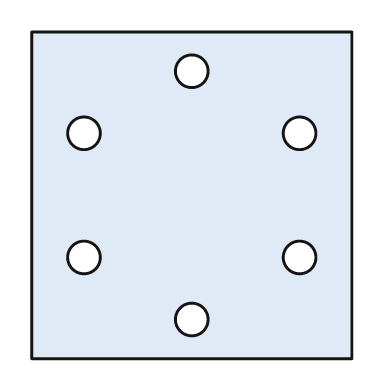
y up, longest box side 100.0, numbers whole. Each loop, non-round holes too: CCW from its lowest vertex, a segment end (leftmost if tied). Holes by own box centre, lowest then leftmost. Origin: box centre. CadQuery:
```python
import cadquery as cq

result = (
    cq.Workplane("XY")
    .moveTo(-49.0, -50.0)
    .lineTo(49.0, -50.0)
    .lineTo(49.0, 50.0)
    .lineTo(-49.0, 50.0)
    .close()
    .moveTo(0.0, -38.0)
    .circle(5.0)
    .moveTo(-33.0, -19.0)
    .circle(5.0)
    .moveTo(33.0, -19.0)
    .circle(5.0)
    .moveTo(-33.0, 19.0)
    .circle(5.0)
    .moveTo(33.0, 19.0)
    .circle(5.0)
    .moveTo(0.0, 38.0)
    .circle(5.0)
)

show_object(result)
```